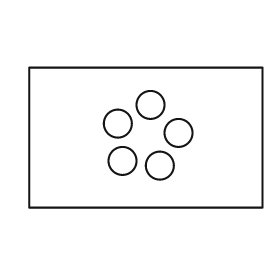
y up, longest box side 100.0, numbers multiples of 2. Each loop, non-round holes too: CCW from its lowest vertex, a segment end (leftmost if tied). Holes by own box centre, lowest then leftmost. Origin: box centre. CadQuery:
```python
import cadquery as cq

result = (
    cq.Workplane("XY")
    .moveTo(-50.0, -30.0)
    .lineTo(50.0, -30.0)
    .lineTo(50.0, 30.0)
    .lineTo(-50.0, 30.0)
    .close()
    .moveTo(6.0, -12.0)
    .circle(6.0)
    .moveTo(-10.0, -10.0)
    .circle(6.0)
    .moveTo(14.0, 2.0)
    .circle(6.0)
    .moveTo(-12.0, 6.0)
    .circle(6.0)
    .moveTo(2.0, 14.0)
    .circle(6.0)
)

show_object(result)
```